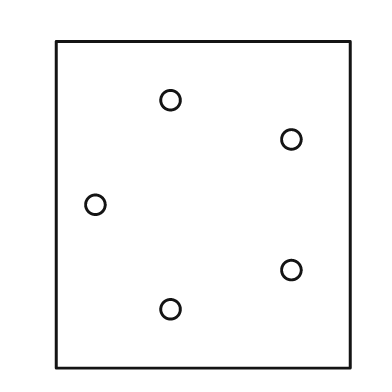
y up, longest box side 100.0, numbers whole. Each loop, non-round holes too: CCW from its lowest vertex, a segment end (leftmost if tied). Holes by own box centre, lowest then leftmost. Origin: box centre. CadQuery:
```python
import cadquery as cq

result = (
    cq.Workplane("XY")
    .moveTo(-45.0, -50.0)
    .lineTo(45.0, -50.0)
    .lineTo(45.0, 50.0)
    .lineTo(-45.0, 50.0)
    .close()
    .moveTo(-10.0, -32.0)
    .circle(3.0)
    .moveTo(27.0, -20.0)
    .circle(3.0)
    .moveTo(-33.0, 0.0)
    .circle(3.0)
    .moveTo(27.0, 20.0)
    .circle(3.0)
    .moveTo(-10.0, 32.0)
    .circle(3.0)
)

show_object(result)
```